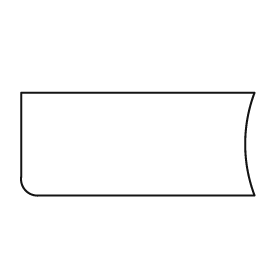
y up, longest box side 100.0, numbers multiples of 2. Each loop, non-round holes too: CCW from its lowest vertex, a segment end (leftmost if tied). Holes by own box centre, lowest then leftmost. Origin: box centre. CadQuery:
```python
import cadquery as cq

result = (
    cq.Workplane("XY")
    .moveTo(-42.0, -22.0)
    .lineTo(50.0, -22.0)
    .threePointArc((46.0, 0.0), (50.0, 22.0))
    .lineTo(-50.0, 22.0)
    .lineTo(-50.0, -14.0)
    .threePointArc((-48.0, -20.0), (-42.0, -22.0))
    .close()
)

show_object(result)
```